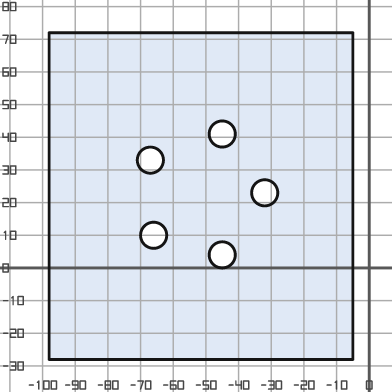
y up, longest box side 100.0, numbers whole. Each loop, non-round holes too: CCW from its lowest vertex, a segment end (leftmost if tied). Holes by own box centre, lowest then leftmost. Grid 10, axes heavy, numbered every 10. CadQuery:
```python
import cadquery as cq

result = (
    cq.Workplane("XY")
    .moveTo(-98.0, -28.0)
    .lineTo(-5.0, -28.0)
    .lineTo(-5.0, 72.0)
    .lineTo(-98.0, 72.0)
    .close()
    .moveTo(-45.0, 4.0)
    .circle(4.0)
    .moveTo(-66.0, 10.0)
    .circle(4.0)
    .moveTo(-32.0, 23.0)
    .circle(4.0)
    .moveTo(-67.0, 33.0)
    .circle(4.0)
    .moveTo(-45.0, 41.0)
    .circle(4.0)
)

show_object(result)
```